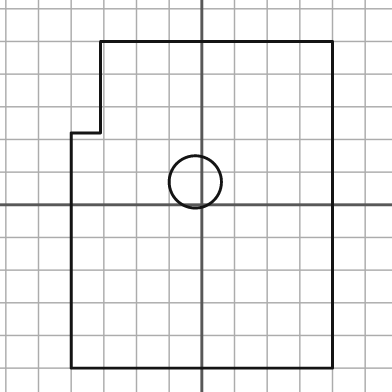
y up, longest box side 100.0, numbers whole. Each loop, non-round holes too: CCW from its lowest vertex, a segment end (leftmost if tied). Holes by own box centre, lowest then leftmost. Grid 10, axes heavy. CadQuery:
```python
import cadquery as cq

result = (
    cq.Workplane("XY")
    .moveTo(-40.0, -50.0)
    .lineTo(40.0, -50.0)
    .lineTo(40.0, 50.0)
    .lineTo(-31.0, 50.0)
    .lineTo(-31.0, 22.0)
    .lineTo(-40.0, 22.0)
    .close()
    .moveTo(-2.0, 7.0)
    .circle(8.0)
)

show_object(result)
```